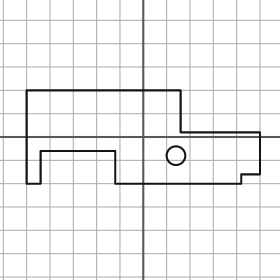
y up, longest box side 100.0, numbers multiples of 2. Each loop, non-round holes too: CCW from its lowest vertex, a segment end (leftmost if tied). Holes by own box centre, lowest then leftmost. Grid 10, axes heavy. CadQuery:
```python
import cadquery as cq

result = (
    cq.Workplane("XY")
    .moveTo(-50.0, -20.0)
    .lineTo(-44.0, -20.0)
    .lineTo(-44.0, -6.0)
    .lineTo(-12.0, -6.0)
    .lineTo(-12.0, -20.0)
    .lineTo(42.0, -20.0)
    .lineTo(42.0, -16.0)
    .lineTo(50.0, -16.0)
    .lineTo(50.0, 2.0)
    .lineTo(16.0, 2.0)
    .lineTo(16.0, 20.0)
    .lineTo(-50.0, 20.0)
    .close()
    .moveTo(14.0, -8.0)
    .circle(4.0)
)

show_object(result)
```